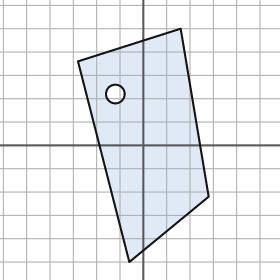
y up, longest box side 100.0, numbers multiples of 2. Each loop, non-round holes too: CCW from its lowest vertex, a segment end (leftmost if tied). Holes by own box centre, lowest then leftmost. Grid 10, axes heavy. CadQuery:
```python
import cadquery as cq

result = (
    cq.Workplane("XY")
    .moveTo(-6.0, -50.0)
    .lineTo(28.0, -22.0)
    .lineTo(16.0, 50.0)
    .lineTo(-28.0, 36.0)
    .close()
    .moveTo(-12.0, 22.0)
    .circle(4.0)
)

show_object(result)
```